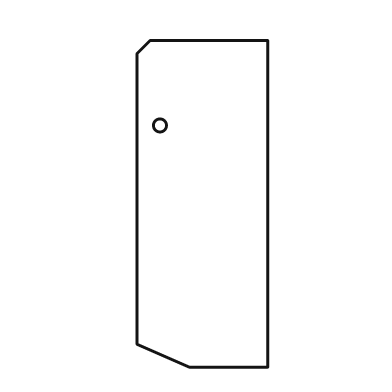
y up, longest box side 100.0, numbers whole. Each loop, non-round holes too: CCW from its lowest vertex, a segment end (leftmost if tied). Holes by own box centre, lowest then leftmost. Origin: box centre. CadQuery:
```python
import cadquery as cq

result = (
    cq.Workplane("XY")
    .moveTo(-4.0, -50.0)
    .lineTo(20.0, -50.0)
    .lineTo(20.0, 50.0)
    .lineTo(-16.0, 50.0)
    .lineTo(-20.0, 46.0)
    .lineTo(-20.0, -43.0)
    .close()
    .moveTo(-13.0, 24.0)
    .circle(2.0)
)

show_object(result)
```